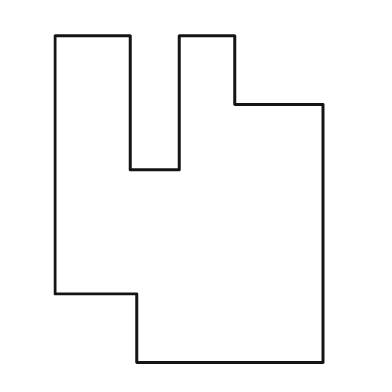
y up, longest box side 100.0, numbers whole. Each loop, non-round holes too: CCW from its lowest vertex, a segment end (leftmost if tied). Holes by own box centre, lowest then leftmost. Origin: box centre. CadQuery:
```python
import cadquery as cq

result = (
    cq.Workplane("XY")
    .moveTo(-16.0, -50.0)
    .lineTo(41.0, -50.0)
    .lineTo(41.0, 29.0)
    .lineTo(14.0, 29.0)
    .lineTo(14.0, 50.0)
    .lineTo(-3.0, 50.0)
    .lineTo(-3.0, 9.0)
    .lineTo(-18.0, 9.0)
    .lineTo(-18.0, 50.0)
    .lineTo(-41.0, 50.0)
    .lineTo(-41.0, -29.0)
    .lineTo(-16.0, -29.0)
    .close()
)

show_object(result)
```